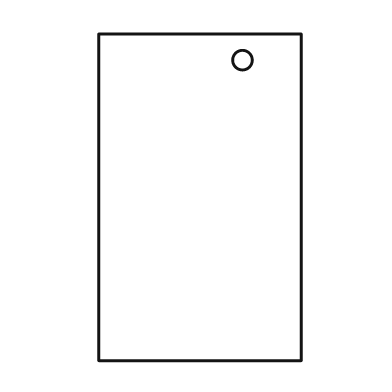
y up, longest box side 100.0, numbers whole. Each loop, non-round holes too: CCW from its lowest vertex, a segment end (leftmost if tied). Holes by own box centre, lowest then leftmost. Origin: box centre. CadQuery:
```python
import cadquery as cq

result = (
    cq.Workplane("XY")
    .moveTo(-31.0, -50.0)
    .lineTo(31.0, -50.0)
    .lineTo(31.0, 50.0)
    .lineTo(-31.0, 50.0)
    .close()
    .moveTo(13.0, 42.0)
    .circle(3.0)
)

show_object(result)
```